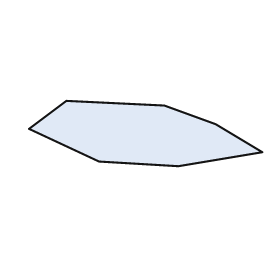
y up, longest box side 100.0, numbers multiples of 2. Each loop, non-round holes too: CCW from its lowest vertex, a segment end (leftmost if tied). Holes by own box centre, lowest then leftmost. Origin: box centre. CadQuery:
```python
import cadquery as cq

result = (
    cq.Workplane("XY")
    .moveTo(14.0, -14.0)
    .lineTo(50.0, -8.0)
    .lineTo(30.0, 4.0)
    .lineTo(8.0, 12.0)
    .lineTo(-34.0, 14.0)
    .lineTo(-50.0, 2.0)
    .lineTo(-20.0, -12.0)
    .close()
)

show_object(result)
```